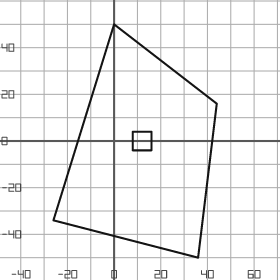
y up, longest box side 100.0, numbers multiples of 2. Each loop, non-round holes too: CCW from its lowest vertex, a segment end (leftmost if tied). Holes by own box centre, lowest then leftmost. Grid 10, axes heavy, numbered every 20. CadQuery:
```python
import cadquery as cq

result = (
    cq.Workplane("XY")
    .moveTo(36.0, -50.0)
    .lineTo(44.0, 16.0)
    .lineTo(0.0, 50.0)
    .lineTo(-26.0, -34.0)
    .close()
    .moveTo(8.0, -4.0)
    .lineTo(16.0, -4.0)
    .lineTo(16.0, 4.0)
    .lineTo(8.0, 4.0)
    .close()
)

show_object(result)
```